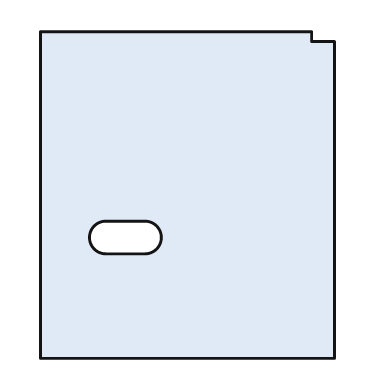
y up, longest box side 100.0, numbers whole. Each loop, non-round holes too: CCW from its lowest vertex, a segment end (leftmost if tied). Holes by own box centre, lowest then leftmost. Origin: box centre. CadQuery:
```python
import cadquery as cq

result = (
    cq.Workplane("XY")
    .moveTo(-45.0, -50.0)
    .lineTo(45.0, -50.0)
    .lineTo(45.0, 47.0)
    .lineTo(38.0, 47.0)
    .lineTo(38.0, 50.0)
    .lineTo(-45.0, 50.0)
    .close()
    .moveTo(-25.0, -18.0)
    .lineTo(-13.0, -18.0)
    .threePointArc((-8.0, -13.0), (-13.0, -8.0))
    .lineTo(-25.0, -8.0)
    .threePointArc((-30.0, -13.0), (-25.0, -18.0))
    .close()
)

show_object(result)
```